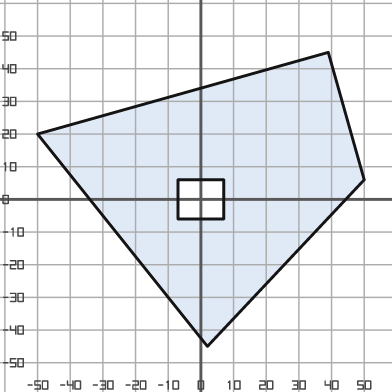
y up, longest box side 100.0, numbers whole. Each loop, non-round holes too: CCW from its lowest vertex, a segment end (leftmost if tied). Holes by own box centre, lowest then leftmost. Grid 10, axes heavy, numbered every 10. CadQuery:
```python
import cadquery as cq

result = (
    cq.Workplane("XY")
    .moveTo(2.0, -45.0)
    .lineTo(50.0, 6.0)
    .lineTo(39.0, 45.0)
    .lineTo(-50.0, 20.0)
    .close()
    .moveTo(-7.0, -6.0)
    .lineTo(7.0, -6.0)
    .lineTo(7.0, 6.0)
    .lineTo(-7.0, 6.0)
    .close()
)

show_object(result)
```